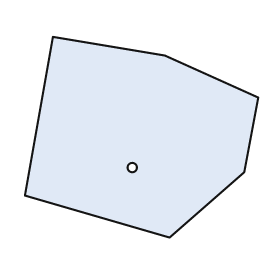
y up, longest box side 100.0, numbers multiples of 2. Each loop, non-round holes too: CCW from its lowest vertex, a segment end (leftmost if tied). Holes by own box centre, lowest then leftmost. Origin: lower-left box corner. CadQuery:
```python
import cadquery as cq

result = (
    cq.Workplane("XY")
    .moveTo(62.0, 0.0)
    .lineTo(94.0, 28.0)
    .lineTo(100.0, 60.0)
    .lineTo(60.0, 78.0)
    .lineTo(12.0, 86.0)
    .lineTo(0.0, 18.0)
    .close()
    .moveTo(46.0, 30.0)
    .circle(2.0)
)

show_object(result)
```